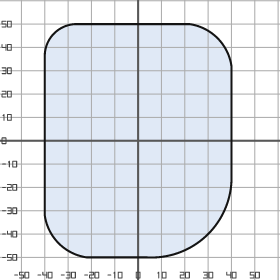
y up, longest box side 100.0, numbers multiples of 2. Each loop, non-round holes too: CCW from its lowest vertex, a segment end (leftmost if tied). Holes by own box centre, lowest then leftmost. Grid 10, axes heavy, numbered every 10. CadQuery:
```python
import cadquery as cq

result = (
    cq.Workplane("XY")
    .moveTo(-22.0, -50.0)
    .lineTo(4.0, -50.0)
    .threePointArc((30.0, -40.0), (40.0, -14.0))
    .lineTo(40.0, 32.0)
    .threePointArc((34.0, 44.0), (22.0, 50.0))
    .lineTo(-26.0, 50.0)
    .threePointArc((-36.0, 46.0), (-40.0, 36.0))
    .lineTo(-40.0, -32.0)
    .threePointArc((-34.0, -44.0), (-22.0, -50.0))
    .close()
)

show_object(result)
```